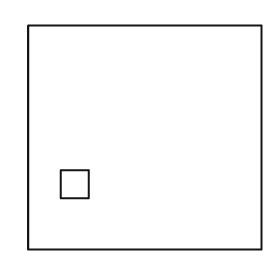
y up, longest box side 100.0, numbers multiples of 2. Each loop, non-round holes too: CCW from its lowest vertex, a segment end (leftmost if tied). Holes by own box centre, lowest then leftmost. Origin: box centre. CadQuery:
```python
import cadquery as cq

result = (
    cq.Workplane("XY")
    .moveTo(-50.0, -48.0)
    .lineTo(50.0, -48.0)
    .lineTo(50.0, 48.0)
    .lineTo(-50.0, 48.0)
    .close()
    .moveTo(-36.0, -26.0)
    .lineTo(-24.0, -26.0)
    .lineTo(-24.0, -14.0)
    .lineTo(-36.0, -14.0)
    .close()
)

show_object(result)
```